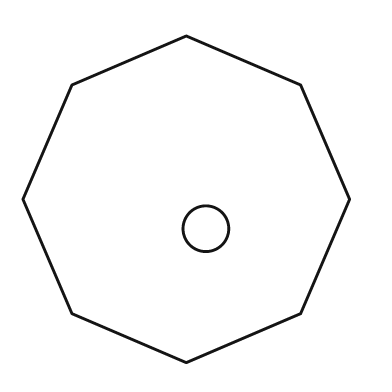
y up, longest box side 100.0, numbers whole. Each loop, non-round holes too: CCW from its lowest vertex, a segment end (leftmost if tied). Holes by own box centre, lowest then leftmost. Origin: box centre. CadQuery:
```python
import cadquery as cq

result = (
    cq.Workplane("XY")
    .moveTo(0.0, -50.0)
    .lineTo(35.0, -35.0)
    .lineTo(50.0, 0.0)
    .lineTo(35.0, 35.0)
    .lineTo(0.0, 50.0)
    .lineTo(-35.0, 35.0)
    .lineTo(-50.0, 0.0)
    .lineTo(-35.0, -35.0)
    .close()
    .moveTo(6.0, -9.0)
    .circle(7.0)
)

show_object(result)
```